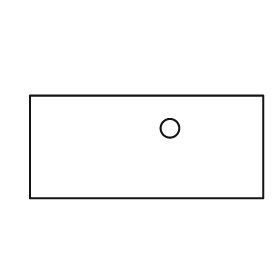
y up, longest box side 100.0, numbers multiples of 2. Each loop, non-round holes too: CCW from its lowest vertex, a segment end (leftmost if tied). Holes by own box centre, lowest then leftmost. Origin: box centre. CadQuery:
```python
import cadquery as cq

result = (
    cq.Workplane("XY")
    .moveTo(-50.0, -22.0)
    .lineTo(50.0, -22.0)
    .lineTo(50.0, 22.0)
    .lineTo(-50.0, 22.0)
    .close()
    .moveTo(10.0, 8.0)
    .circle(4.0)
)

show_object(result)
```